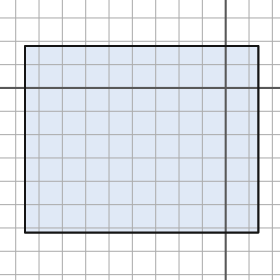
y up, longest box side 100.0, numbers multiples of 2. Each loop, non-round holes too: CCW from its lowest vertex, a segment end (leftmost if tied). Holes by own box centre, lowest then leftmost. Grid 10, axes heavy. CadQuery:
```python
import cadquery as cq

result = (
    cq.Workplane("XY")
    .moveTo(-86.0, -62.0)
    .lineTo(14.0, -62.0)
    .lineTo(14.0, 18.0)
    .lineTo(-86.0, 18.0)
    .close()
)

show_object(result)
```